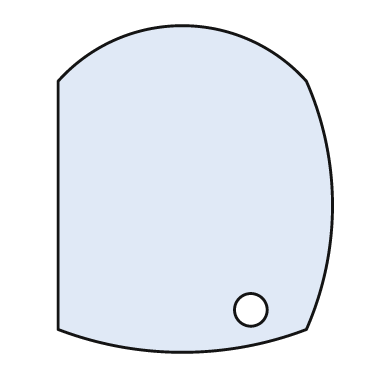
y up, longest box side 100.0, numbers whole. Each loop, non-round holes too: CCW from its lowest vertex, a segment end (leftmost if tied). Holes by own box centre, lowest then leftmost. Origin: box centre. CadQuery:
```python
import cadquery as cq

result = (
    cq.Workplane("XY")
    .moveTo(-42.0, -43.0)
    .threePointArc((-4.0, -50.0), (34.0, -43.0))
    .threePointArc((42.0, -5.0), (34.0, 33.0))
    .threePointArc((-4.0, 50.0), (-42.0, 33.0))
    .close()
    .moveTo(17.0, -37.0)
    .circle(5.0)
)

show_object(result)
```